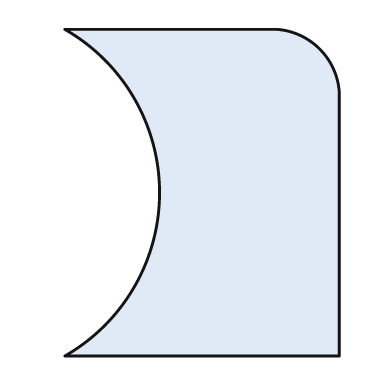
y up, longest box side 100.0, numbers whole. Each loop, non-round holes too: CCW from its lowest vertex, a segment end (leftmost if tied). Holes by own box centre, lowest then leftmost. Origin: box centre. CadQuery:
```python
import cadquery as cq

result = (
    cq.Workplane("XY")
    .moveTo(-42.0, -50.0)
    .lineTo(42.0, -50.0)
    .lineTo(42.0, 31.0)
    .threePointArc((36.0, 44.0), (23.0, 50.0))
    .lineTo(-42.0, 50.0)
    .threePointArc((-13.0, 0.0), (-42.0, -50.0))
    .close()
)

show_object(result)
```